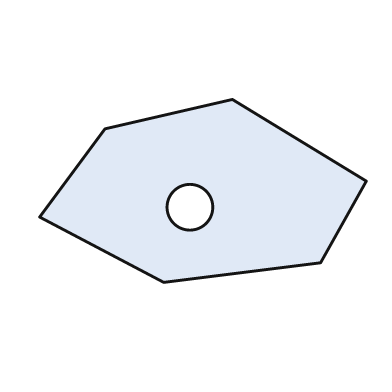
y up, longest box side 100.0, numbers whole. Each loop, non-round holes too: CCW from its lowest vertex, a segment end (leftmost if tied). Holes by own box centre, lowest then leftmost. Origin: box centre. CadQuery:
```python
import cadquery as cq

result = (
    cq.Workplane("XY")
    .moveTo(-12.0, -28.0)
    .lineTo(36.0, -22.0)
    .lineTo(50.0, 3.0)
    .lineTo(9.0, 28.0)
    .lineTo(-30.0, 19.0)
    .lineTo(-50.0, -8.0)
    .close()
    .moveTo(-4.0, -5.0)
    .circle(7.0)
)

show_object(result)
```